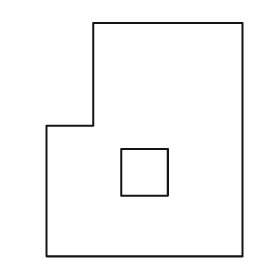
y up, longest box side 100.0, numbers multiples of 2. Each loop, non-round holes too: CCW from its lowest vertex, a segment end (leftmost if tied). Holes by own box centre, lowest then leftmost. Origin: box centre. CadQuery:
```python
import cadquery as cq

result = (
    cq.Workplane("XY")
    .moveTo(-42.0, -50.0)
    .lineTo(42.0, -50.0)
    .lineTo(42.0, 50.0)
    .lineTo(-22.0, 50.0)
    .lineTo(-22.0, 6.0)
    .lineTo(-42.0, 6.0)
    .close()
    .moveTo(-10.0, -24.0)
    .lineTo(10.0, -24.0)
    .lineTo(10.0, -4.0)
    .lineTo(-10.0, -4.0)
    .close()
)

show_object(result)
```